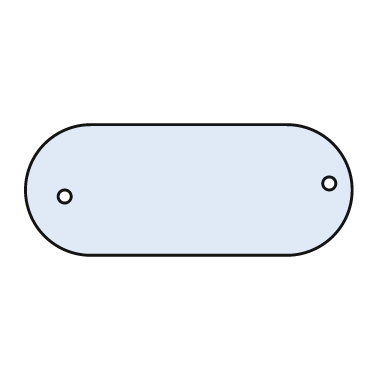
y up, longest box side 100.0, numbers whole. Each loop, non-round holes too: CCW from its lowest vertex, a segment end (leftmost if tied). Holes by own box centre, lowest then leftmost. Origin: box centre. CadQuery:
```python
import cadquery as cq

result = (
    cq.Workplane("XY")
    .moveTo(-30.0, -20.0)
    .lineTo(30.0, -20.0)
    .threePointArc((50.0, 0.0), (30.0, 20.0))
    .lineTo(-30.0, 20.0)
    .threePointArc((-50.0, 0.0), (-30.0, -20.0))
    .close()
    .moveTo(-38.0, -2.0)
    .circle(2.0)
    .moveTo(43.0, 2.0)
    .circle(2.0)
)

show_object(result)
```